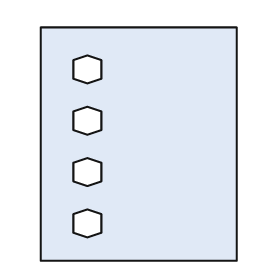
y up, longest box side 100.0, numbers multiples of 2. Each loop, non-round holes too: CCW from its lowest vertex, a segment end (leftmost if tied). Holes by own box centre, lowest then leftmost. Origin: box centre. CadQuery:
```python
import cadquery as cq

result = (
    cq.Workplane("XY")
    .moveTo(-42.0, -50.0)
    .lineTo(42.0, -50.0)
    .lineTo(42.0, 50.0)
    .lineTo(-42.0, 50.0)
    .close()
    .moveTo(-22.0, -40.0)
    .lineTo(-16.0, -38.0)
    .lineTo(-16.0, -30.0)
    .lineTo(-22.0, -28.0)
    .lineTo(-28.0, -30.0)
    .lineTo(-28.0, -38.0)
    .close()
    .moveTo(-22.0, -18.0)
    .lineTo(-16.0, -16.0)
    .lineTo(-16.0, -8.0)
    .lineTo(-22.0, -6.0)
    .lineTo(-28.0, -8.0)
    .lineTo(-28.0, -16.0)
    .close()
    .moveTo(-22.0, 4.0)
    .lineTo(-16.0, 6.0)
    .lineTo(-16.0, 14.0)
    .lineTo(-22.0, 16.0)
    .lineTo(-28.0, 14.0)
    .lineTo(-28.0, 6.0)
    .close()
    .moveTo(-22.0, 26.0)
    .lineTo(-16.0, 28.0)
    .lineTo(-16.0, 36.0)
    .lineTo(-22.0, 38.0)
    .lineTo(-28.0, 36.0)
    .lineTo(-28.0, 28.0)
    .close()
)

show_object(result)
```